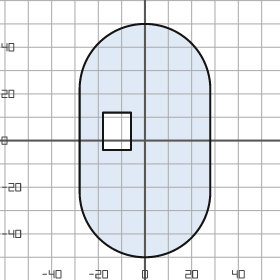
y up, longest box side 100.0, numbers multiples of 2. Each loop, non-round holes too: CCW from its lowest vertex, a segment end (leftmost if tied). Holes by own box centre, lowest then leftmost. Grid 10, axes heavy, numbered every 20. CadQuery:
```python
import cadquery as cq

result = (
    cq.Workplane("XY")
    .moveTo(-28.0, -22.0)
    .threePointArc((0.0, -50.0), (28.0, -22.0))
    .lineTo(28.0, 22.0)
    .threePointArc((0.0, 50.0), (-28.0, 22.0))
    .close()
    .moveTo(-18.0, -4.0)
    .lineTo(-6.0, -4.0)
    .lineTo(-6.0, 12.0)
    .lineTo(-18.0, 12.0)
    .close()
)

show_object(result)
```